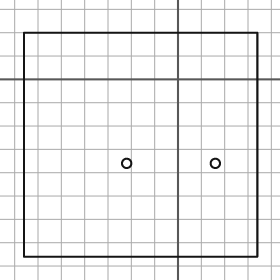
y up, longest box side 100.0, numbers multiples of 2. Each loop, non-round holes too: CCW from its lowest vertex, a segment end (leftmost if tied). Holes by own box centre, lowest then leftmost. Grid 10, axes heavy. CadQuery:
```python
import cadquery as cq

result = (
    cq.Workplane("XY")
    .moveTo(-66.0, -76.0)
    .lineTo(34.0, -76.0)
    .lineTo(34.0, 20.0)
    .lineTo(-66.0, 20.0)
    .close()
    .moveTo(-22.0, -36.0)
    .circle(2.0)
    .moveTo(16.0, -36.0)
    .circle(2.0)
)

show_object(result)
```